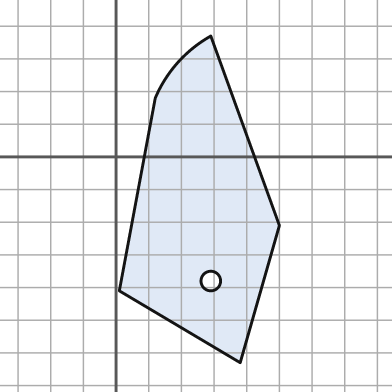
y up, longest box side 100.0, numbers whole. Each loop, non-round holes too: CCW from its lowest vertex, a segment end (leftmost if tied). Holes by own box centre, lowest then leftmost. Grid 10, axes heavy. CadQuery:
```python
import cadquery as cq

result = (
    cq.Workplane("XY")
    .moveTo(38.0, -63.0)
    .lineTo(50.0, -21.0)
    .lineTo(29.0, 37.0)
    .threePointArc((19.0, 29.0), (12.0, 18.0))
    .lineTo(1.0, -41.0)
    .close()
    .moveTo(29.0, -38.0)
    .circle(3.0)
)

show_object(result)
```